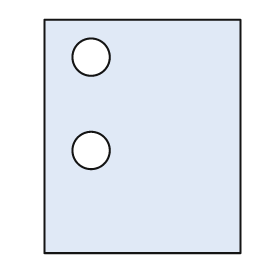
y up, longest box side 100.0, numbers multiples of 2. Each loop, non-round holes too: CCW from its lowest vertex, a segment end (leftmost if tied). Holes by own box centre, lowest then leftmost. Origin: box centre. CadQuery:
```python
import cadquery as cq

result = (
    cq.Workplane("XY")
    .moveTo(-42.0, -50.0)
    .lineTo(42.0, -50.0)
    .lineTo(42.0, 50.0)
    .lineTo(-42.0, 50.0)
    .close()
    .moveTo(-22.0, -6.0)
    .circle(8.0)
    .moveTo(-22.0, 34.0)
    .circle(8.0)
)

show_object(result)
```